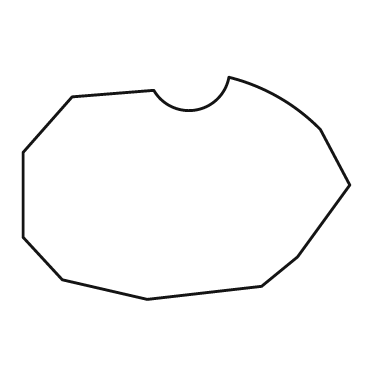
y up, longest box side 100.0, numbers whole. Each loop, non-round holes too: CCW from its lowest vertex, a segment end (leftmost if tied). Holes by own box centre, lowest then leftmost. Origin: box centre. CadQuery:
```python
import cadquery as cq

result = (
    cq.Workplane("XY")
    .moveTo(-12.0, -34.0)
    .lineTo(23.0, -30.0)
    .lineTo(34.0, -21.0)
    .lineTo(50.0, 1.0)
    .lineTo(41.0, 18.0)
    .threePointArc((28.0, 28.0), (13.0, 34.0))
    .threePointArc((3.0, 24.0), (-10.0, 30.0))
    .lineTo(-35.0, 28.0)
    .lineTo(-50.0, 11.0)
    .lineTo(-50.0, -15.0)
    .lineTo(-38.0, -28.0)
    .close()
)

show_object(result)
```